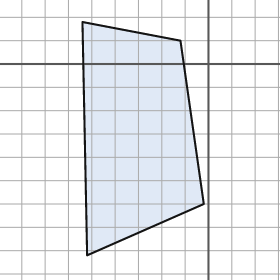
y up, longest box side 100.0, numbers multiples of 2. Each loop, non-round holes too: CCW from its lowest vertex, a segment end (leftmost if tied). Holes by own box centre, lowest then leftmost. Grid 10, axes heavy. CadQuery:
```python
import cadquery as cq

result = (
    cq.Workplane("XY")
    .moveTo(-52.0, -82.0)
    .lineTo(-2.0, -60.0)
    .lineTo(-12.0, 10.0)
    .lineTo(-54.0, 18.0)
    .close()
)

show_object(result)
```